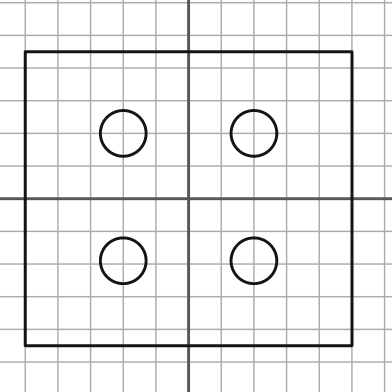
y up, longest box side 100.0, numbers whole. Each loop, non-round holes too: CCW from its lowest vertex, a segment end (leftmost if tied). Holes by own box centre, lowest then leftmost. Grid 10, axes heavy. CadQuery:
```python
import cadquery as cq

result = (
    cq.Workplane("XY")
    .moveTo(-50.0, -45.0)
    .lineTo(50.0, -45.0)
    .lineTo(50.0, 45.0)
    .lineTo(-50.0, 45.0)
    .close()
    .moveTo(-20.0, -19.0)
    .circle(7.0)
    .moveTo(20.0, -19.0)
    .circle(7.0)
    .moveTo(-20.0, 20.0)
    .circle(7.0)
    .moveTo(20.0, 20.0)
    .circle(7.0)
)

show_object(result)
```